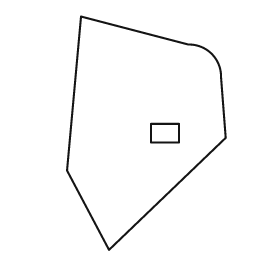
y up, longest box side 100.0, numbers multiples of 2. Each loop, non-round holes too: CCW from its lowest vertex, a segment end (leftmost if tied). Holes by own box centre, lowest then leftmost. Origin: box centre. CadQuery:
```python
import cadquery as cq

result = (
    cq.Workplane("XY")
    .moveTo(-16.0, -50.0)
    .lineTo(34.0, -2.0)
    .lineTo(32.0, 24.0)
    .threePointArc((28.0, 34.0), (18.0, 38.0))
    .lineTo(-28.0, 50.0)
    .lineTo(-34.0, -16.0)
    .close()
    .moveTo(2.0, -4.0)
    .lineTo(14.0, -4.0)
    .lineTo(14.0, 4.0)
    .lineTo(2.0, 4.0)
    .close()
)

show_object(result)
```